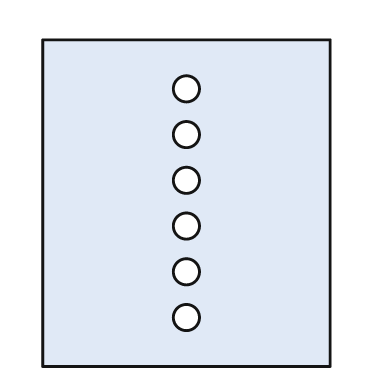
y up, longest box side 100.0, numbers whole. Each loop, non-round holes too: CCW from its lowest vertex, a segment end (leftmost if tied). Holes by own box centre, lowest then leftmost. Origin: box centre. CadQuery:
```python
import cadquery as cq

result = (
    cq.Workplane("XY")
    .moveTo(-44.0, -50.0)
    .lineTo(44.0, -50.0)
    .lineTo(44.0, 50.0)
    .lineTo(-44.0, 50.0)
    .close()
    .moveTo(0.0, -35.0)
    .circle(4.0)
    .moveTo(0.0, -21.0)
    .circle(4.0)
    .moveTo(0.0, -7.0)
    .circle(4.0)
    .moveTo(0.0, 7.0)
    .circle(4.0)
    .moveTo(0.0, 21.0)
    .circle(4.0)
    .moveTo(0.0, 35.0)
    .circle(4.0)
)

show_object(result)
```